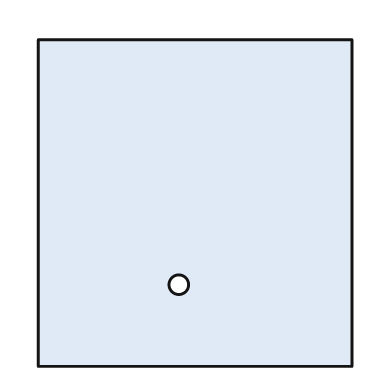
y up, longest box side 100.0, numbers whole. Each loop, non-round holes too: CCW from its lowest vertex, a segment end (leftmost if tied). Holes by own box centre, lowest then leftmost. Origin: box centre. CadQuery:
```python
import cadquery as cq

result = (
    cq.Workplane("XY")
    .moveTo(-48.0, -50.0)
    .lineTo(48.0, -50.0)
    .lineTo(48.0, 50.0)
    .lineTo(-48.0, 50.0)
    .close()
    .moveTo(-5.0, -25.0)
    .circle(3.0)
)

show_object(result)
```